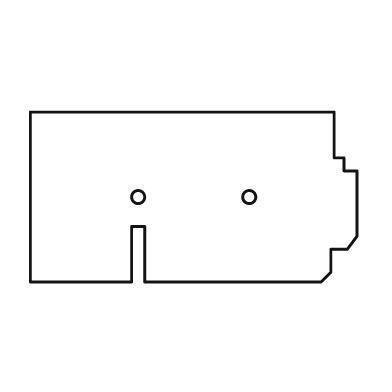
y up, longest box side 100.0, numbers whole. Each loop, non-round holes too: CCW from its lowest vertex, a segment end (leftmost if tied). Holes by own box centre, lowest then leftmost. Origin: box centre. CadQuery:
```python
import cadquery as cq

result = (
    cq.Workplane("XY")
    .moveTo(-50.0, -26.0)
    .lineTo(-19.0, -26.0)
    .lineTo(-19.0, -9.0)
    .lineTo(-15.0, -9.0)
    .lineTo(-15.0, -26.0)
    .lineTo(39.0, -26.0)
    .lineTo(42.0, -23.0)
    .lineTo(42.0, -16.0)
    .lineTo(47.0, -16.0)
    .lineTo(50.0, -12.0)
    .lineTo(50.0, 8.0)
    .lineTo(46.0, 8.0)
    .lineTo(46.0, 12.0)
    .lineTo(43.0, 12.0)
    .lineTo(43.0, 26.0)
    .lineTo(-50.0, 26.0)
    .close()
    .moveTo(-17.0, 0.0)
    .circle(2.0)
    .moveTo(17.0, 0.0)
    .circle(2.0)
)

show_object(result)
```